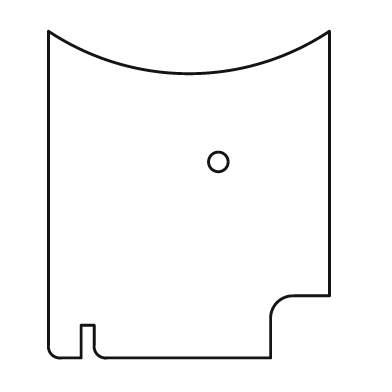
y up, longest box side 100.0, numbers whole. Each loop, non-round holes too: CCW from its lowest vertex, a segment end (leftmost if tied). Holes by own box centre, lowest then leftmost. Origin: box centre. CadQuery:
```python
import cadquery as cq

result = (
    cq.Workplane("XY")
    .moveTo(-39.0, -50.0)
    .lineTo(-33.0, -50.0)
    .lineTo(-33.0, -40.0)
    .lineTo(-29.0, -40.0)
    .lineTo(-29.0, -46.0)
    .threePointArc((-28.0, -49.0), (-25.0, -50.0))
    .lineTo(25.0, -50.0)
    .lineTo(25.0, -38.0)
    .threePointArc((27.0, -33.0), (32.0, -31.0))
    .lineTo(43.0, -31.0)
    .lineTo(43.0, 50.0)
    .threePointArc((0.0, 37.0), (-43.0, 50.0))
    .lineTo(-43.0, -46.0)
    .threePointArc((-42.0, -49.0), (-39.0, -50.0))
    .close()
    .moveTo(9.0, 10.0)
    .circle(3.0)
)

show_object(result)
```